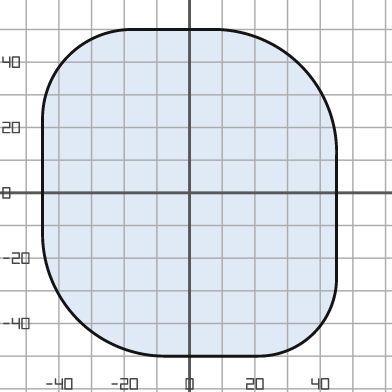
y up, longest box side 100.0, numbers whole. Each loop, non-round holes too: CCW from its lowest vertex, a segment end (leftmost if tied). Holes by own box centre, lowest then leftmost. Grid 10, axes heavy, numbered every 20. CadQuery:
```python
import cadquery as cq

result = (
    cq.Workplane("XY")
    .moveTo(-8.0, -50.0)
    .lineTo(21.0, -50.0)
    .threePointArc((38.0, -43.0), (45.0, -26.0))
    .lineTo(45.0, 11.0)
    .threePointArc((34.0, 39.0), (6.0, 50.0))
    .lineTo(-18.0, 50.0)
    .threePointArc((-37.0, 42.0), (-45.0, 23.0))
    .lineTo(-45.0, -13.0)
    .threePointArc((-34.0, -39.0), (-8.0, -50.0))
    .close()
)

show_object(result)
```